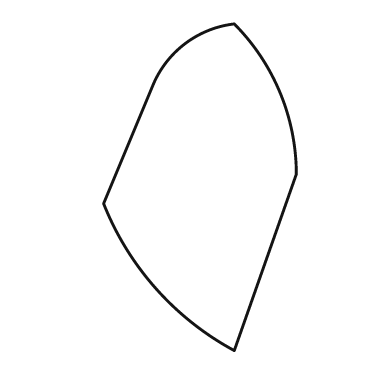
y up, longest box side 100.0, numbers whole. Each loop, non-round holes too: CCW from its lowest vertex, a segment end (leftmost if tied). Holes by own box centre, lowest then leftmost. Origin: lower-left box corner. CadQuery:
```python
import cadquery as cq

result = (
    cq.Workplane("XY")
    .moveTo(40.0, 0.0)
    .lineTo(59.0, 54.0)
    .threePointArc((54.0, 79.0), (40.0, 100.0))
    .threePointArc((25.0, 94.0), (15.0, 81.0))
    .lineTo(0.0, 45.0)
    .threePointArc((16.0, 19.0), (40.0, 0.0))
    .close()
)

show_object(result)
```